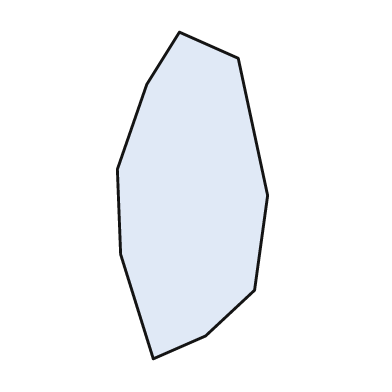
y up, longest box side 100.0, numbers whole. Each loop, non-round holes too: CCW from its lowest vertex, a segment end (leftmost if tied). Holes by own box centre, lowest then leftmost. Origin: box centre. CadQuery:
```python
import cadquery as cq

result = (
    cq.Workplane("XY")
    .moveTo(-12.0, -50.0)
    .lineTo(4.0, -43.0)
    .lineTo(19.0, -29.0)
    .lineTo(23.0, 0.0)
    .lineTo(14.0, 42.0)
    .lineTo(-4.0, 50.0)
    .lineTo(-14.0, 34.0)
    .lineTo(-23.0, 8.0)
    .lineTo(-22.0, -18.0)
    .close()
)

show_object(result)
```